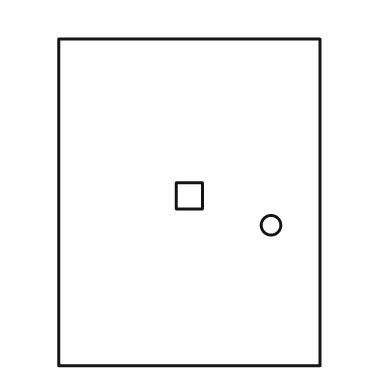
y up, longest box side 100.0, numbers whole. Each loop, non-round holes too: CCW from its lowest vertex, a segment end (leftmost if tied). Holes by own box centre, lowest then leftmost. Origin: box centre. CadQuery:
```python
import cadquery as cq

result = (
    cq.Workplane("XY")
    .moveTo(-40.0, -50.0)
    .lineTo(40.0, -50.0)
    .lineTo(40.0, 50.0)
    .lineTo(-40.0, 50.0)
    .close()
    .moveTo(25.0, -7.0)
    .circle(3.0)
    .moveTo(-4.0, -2.0)
    .lineTo(4.0, -2.0)
    .lineTo(4.0, 6.0)
    .lineTo(-4.0, 6.0)
    .close()
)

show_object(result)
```